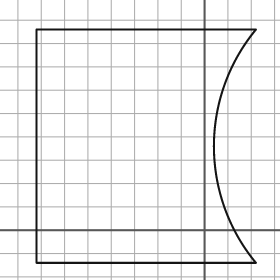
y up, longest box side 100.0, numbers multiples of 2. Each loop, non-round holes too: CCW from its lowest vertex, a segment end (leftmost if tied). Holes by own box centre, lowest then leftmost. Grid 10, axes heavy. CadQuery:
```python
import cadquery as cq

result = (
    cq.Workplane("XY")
    .moveTo(-72.0, -14.0)
    .lineTo(22.0, -14.0)
    .threePointArc((4.0, 36.0), (22.0, 86.0))
    .lineTo(-72.0, 86.0)
    .close()
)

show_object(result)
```